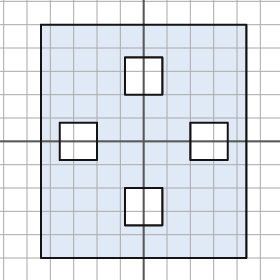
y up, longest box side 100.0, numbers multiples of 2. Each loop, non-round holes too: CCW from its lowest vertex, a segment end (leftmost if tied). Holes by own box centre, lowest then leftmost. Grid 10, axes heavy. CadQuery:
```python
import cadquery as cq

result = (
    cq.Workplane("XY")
    .moveTo(-44.0, -50.0)
    .lineTo(44.0, -50.0)
    .lineTo(44.0, 50.0)
    .lineTo(-44.0, 50.0)
    .close()
    .moveTo(-8.0, -36.0)
    .lineTo(8.0, -36.0)
    .lineTo(8.0, -20.0)
    .lineTo(-8.0, -20.0)
    .close()
    .moveTo(-36.0, -8.0)
    .lineTo(-20.0, -8.0)
    .lineTo(-20.0, 8.0)
    .lineTo(-36.0, 8.0)
    .close()
    .moveTo(20.0, -8.0)
    .lineTo(36.0, -8.0)
    .lineTo(36.0, 8.0)
    .lineTo(20.0, 8.0)
    .close()
    .moveTo(-8.0, 20.0)
    .lineTo(8.0, 20.0)
    .lineTo(8.0, 36.0)
    .lineTo(-8.0, 36.0)
    .close()
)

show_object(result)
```